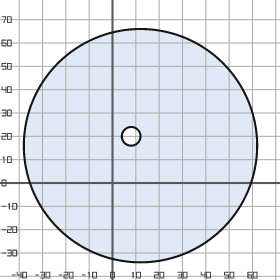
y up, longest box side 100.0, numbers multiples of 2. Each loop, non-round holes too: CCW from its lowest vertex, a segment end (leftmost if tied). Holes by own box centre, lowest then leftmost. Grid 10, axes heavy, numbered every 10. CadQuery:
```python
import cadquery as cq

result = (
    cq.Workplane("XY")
    .moveTo(12.0, 16.0)
    .circle(50.0)
    .moveTo(8.0, 20.0)
    .circle(4.0)
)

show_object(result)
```